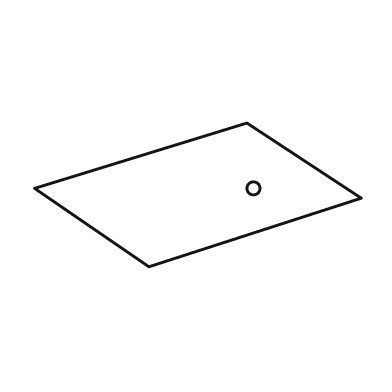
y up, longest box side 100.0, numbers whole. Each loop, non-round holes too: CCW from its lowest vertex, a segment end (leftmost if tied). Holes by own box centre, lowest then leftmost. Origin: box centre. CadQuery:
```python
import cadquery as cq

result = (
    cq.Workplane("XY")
    .moveTo(-15.0, -22.0)
    .lineTo(50.0, -1.0)
    .lineTo(15.0, 22.0)
    .lineTo(-50.0, 2.0)
    .close()
    .moveTo(17.0, 2.0)
    .circle(2.0)
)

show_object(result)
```